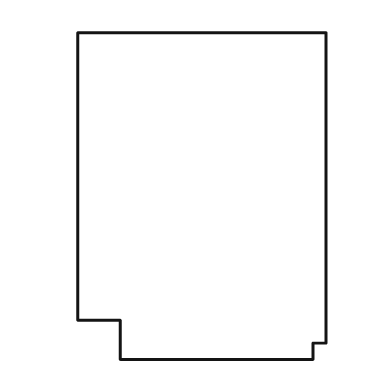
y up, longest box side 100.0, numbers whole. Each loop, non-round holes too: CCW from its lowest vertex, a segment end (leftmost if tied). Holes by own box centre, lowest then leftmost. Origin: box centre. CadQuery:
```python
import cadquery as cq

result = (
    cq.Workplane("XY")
    .moveTo(-25.0, -50.0)
    .lineTo(34.0, -50.0)
    .lineTo(34.0, -45.0)
    .lineTo(38.0, -45.0)
    .lineTo(38.0, 50.0)
    .lineTo(-38.0, 50.0)
    .lineTo(-38.0, -38.0)
    .lineTo(-25.0, -38.0)
    .close()
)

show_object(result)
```